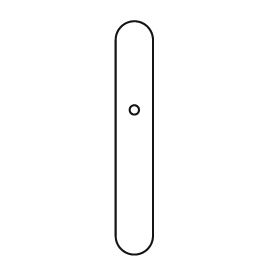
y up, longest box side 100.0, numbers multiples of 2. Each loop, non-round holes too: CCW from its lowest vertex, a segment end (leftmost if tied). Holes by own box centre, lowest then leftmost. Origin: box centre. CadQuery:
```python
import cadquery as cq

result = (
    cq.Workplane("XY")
    .moveTo(-8.0, -42.0)
    .threePointArc((0.0, -50.0), (8.0, -42.0))
    .lineTo(8.0, 42.0)
    .threePointArc((0.0, 50.0), (-8.0, 42.0))
    .close()
    .moveTo(0.0, 12.0)
    .circle(2.0)
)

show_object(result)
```